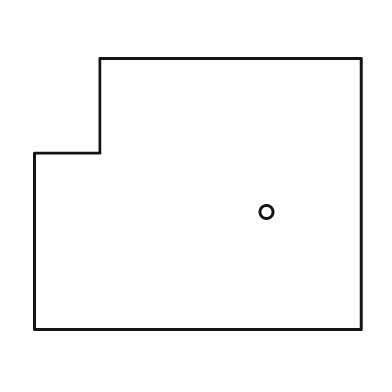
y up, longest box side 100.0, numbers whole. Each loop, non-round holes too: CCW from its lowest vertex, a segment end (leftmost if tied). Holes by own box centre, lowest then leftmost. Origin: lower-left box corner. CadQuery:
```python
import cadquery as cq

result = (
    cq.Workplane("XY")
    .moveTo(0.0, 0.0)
    .lineTo(100.0, 0.0)
    .lineTo(100.0, 83.0)
    .lineTo(20.0, 83.0)
    .lineTo(20.0, 54.0)
    .lineTo(0.0, 54.0)
    .close()
    .moveTo(71.0, 36.0)
    .circle(2.0)
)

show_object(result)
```